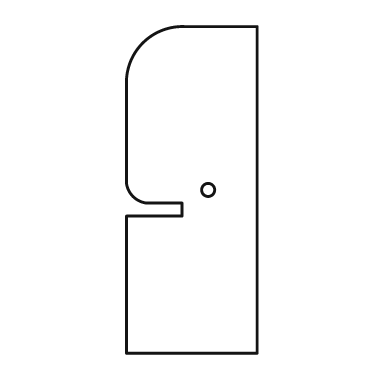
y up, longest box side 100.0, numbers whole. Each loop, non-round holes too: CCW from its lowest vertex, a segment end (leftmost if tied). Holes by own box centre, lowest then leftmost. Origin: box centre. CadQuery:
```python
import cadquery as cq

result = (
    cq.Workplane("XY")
    .moveTo(-20.0, -50.0)
    .lineTo(20.0, -50.0)
    .lineTo(20.0, 50.0)
    .lineTo(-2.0, 50.0)
    .threePointArc((-15.0, 45.0), (-20.0, 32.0))
    .lineTo(-20.0, 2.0)
    .threePointArc((-18.0, -2.0), (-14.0, -4.0))
    .lineTo(-3.0, -4.0)
    .lineTo(-3.0, -8.0)
    .lineTo(-20.0, -8.0)
    .close()
    .moveTo(5.0, 0.0)
    .circle(2.0)
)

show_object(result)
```